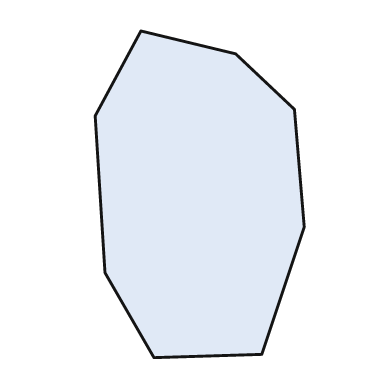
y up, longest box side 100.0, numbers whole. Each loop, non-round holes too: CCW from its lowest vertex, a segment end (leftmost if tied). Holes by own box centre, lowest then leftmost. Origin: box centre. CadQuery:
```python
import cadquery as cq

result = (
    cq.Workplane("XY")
    .moveTo(-14.0, -50.0)
    .lineTo(19.0, -49.0)
    .lineTo(32.0, -10.0)
    .lineTo(29.0, 26.0)
    .lineTo(11.0, 43.0)
    .lineTo(-18.0, 50.0)
    .lineTo(-32.0, 24.0)
    .lineTo(-29.0, -24.0)
    .close()
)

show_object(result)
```